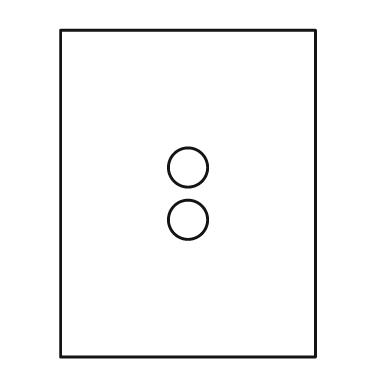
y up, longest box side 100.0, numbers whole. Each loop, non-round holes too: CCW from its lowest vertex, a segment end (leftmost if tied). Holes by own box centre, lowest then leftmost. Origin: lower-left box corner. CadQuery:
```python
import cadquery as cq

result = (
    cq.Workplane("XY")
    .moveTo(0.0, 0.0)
    .lineTo(78.0, 0.0)
    .lineTo(78.0, 100.0)
    .lineTo(0.0, 100.0)
    .close()
    .moveTo(39.0, 42.0)
    .circle(6.0)
    .moveTo(39.0, 58.0)
    .circle(6.0)
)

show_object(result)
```